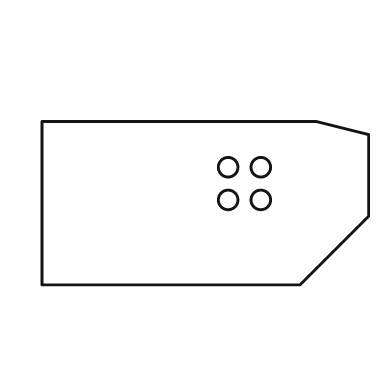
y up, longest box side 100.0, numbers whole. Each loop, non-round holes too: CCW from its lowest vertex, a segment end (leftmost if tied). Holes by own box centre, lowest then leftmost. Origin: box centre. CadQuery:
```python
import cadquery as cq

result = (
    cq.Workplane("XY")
    .moveTo(-50.0, -25.0)
    .lineTo(29.0, -25.0)
    .lineTo(50.0, -4.0)
    .lineTo(50.0, 21.0)
    .lineTo(34.0, 25.0)
    .lineTo(-50.0, 25.0)
    .close()
    .moveTo(7.0, 1.0)
    .circle(3.0)
    .moveTo(17.0, 1.0)
    .circle(3.0)
    .moveTo(7.0, 11.0)
    .circle(3.0)
    .moveTo(17.0, 11.0)
    .circle(3.0)
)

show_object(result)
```